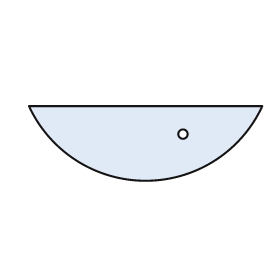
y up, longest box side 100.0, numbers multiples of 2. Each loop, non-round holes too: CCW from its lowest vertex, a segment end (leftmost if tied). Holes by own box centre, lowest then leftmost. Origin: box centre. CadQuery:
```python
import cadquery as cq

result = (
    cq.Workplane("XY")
    .moveTo(-50.0, 16.0)
    .threePointArc((0.0, -16.0), (50.0, 16.0))
    .close()
    .moveTo(16.0, 4.0)
    .circle(2.0)
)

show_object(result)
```